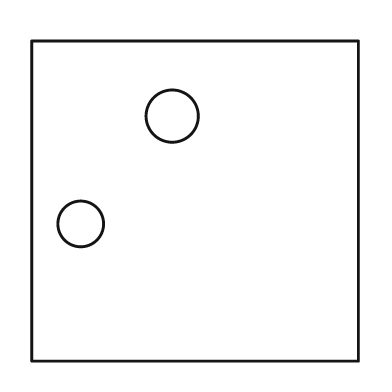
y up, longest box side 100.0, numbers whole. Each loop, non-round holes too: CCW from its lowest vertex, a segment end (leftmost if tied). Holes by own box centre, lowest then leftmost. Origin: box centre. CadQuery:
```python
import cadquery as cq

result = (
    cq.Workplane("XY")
    .moveTo(-50.0, -49.0)
    .lineTo(50.0, -49.0)
    .lineTo(50.0, 49.0)
    .lineTo(-50.0, 49.0)
    .close()
    .moveTo(-35.0, -7.0)
    .circle(7.0)
    .moveTo(-7.0, 26.0)
    .circle(8.0)
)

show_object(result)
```